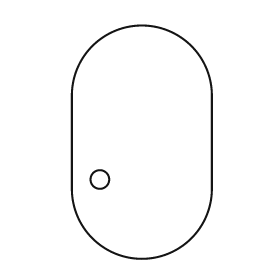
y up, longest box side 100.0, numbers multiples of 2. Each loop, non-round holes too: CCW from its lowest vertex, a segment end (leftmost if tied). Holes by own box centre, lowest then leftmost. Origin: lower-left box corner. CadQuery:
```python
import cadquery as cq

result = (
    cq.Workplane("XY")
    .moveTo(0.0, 30.0)
    .threePointArc((30.0, 0.0), (60.0, 30.0))
    .lineTo(60.0, 70.0)
    .threePointArc((30.0, 100.0), (0.0, 70.0))
    .close()
    .moveTo(12.0, 34.0)
    .circle(4.0)
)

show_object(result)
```